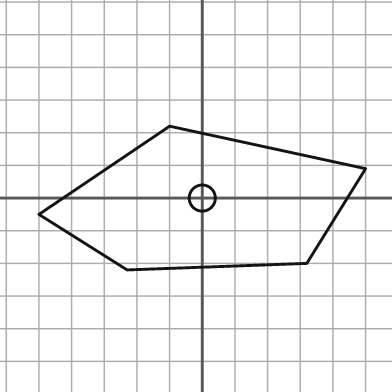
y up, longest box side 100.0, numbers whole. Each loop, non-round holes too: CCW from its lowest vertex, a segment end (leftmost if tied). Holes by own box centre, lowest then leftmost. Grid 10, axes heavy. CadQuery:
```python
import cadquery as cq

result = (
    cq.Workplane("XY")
    .moveTo(-23.0, -22.0)
    .lineTo(32.0, -20.0)
    .lineTo(50.0, 9.0)
    .lineTo(-10.0, 22.0)
    .lineTo(-50.0, -5.0)
    .close()
    .moveTo(0.0, 0.0)
    .circle(4.0)
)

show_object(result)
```